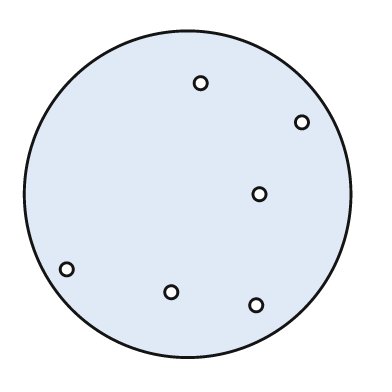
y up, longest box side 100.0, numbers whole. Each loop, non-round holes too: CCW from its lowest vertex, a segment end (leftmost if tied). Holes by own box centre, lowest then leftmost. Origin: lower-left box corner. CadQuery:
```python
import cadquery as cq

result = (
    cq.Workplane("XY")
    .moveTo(50.0, 50.0)
    .circle(50.0)
    .moveTo(71.0, 16.0)
    .circle(2.0)
    .moveTo(45.0, 20.0)
    .circle(2.0)
    .moveTo(13.0, 27.0)
    .circle(2.0)
    .moveTo(72.0, 50.0)
    .circle(2.0)
    .moveTo(85.0, 72.0)
    .circle(2.0)
    .moveTo(54.0, 84.0)
    .circle(2.0)
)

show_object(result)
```